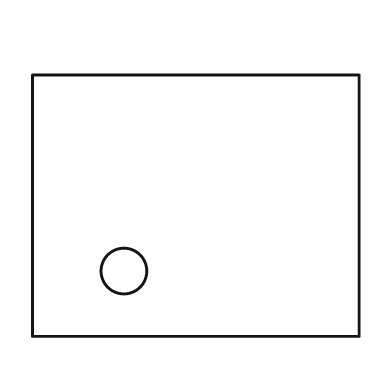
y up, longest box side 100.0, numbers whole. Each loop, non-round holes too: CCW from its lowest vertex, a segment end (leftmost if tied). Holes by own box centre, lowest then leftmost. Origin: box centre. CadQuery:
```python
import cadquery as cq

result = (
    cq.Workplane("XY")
    .moveTo(-50.0, -40.0)
    .lineTo(50.0, -40.0)
    .lineTo(50.0, 40.0)
    .lineTo(-50.0, 40.0)
    .close()
    .moveTo(-22.0, -20.0)
    .circle(7.0)
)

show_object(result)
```